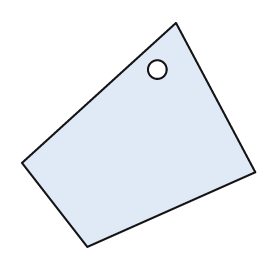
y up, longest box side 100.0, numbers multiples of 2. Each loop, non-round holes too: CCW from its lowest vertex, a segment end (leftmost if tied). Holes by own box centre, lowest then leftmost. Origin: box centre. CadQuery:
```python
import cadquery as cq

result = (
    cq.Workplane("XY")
    .moveTo(-22.0, -48.0)
    .lineTo(50.0, -16.0)
    .lineTo(16.0, 48.0)
    .lineTo(-50.0, -12.0)
    .close()
    .moveTo(8.0, 28.0)
    .circle(4.0)
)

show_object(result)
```